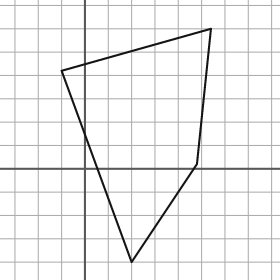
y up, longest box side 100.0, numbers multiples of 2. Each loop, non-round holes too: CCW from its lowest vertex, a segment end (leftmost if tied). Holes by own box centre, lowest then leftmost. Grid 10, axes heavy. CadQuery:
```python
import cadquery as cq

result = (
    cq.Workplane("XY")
    .moveTo(20.0, -40.0)
    .lineTo(48.0, 2.0)
    .lineTo(54.0, 60.0)
    .lineTo(-10.0, 42.0)
    .close()
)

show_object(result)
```